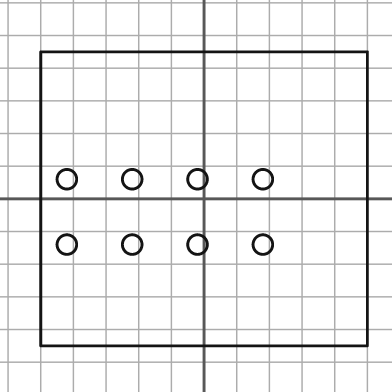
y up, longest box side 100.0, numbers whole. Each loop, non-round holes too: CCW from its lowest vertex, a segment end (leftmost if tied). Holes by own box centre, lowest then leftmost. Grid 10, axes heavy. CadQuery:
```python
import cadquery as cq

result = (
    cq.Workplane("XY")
    .moveTo(-50.0, -45.0)
    .lineTo(50.0, -45.0)
    .lineTo(50.0, 45.0)
    .lineTo(-50.0, 45.0)
    .close()
    .moveTo(-42.0, -14.0)
    .circle(3.0)
    .moveTo(-22.0, -14.0)
    .circle(3.0)
    .moveTo(-2.0, -14.0)
    .circle(3.0)
    .moveTo(18.0, -14.0)
    .circle(3.0)
    .moveTo(-42.0, 6.0)
    .circle(3.0)
    .moveTo(-22.0, 6.0)
    .circle(3.0)
    .moveTo(-2.0, 6.0)
    .circle(3.0)
    .moveTo(18.0, 6.0)
    .circle(3.0)
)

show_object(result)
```